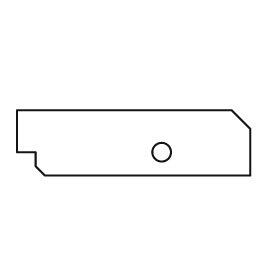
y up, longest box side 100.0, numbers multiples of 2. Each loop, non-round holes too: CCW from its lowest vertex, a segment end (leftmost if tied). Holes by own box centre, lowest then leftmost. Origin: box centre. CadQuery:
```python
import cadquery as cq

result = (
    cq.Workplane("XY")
    .moveTo(-38.0, -14.0)
    .lineTo(50.0, -14.0)
    .lineTo(50.0, 6.0)
    .lineTo(42.0, 14.0)
    .lineTo(-50.0, 14.0)
    .lineTo(-50.0, -4.0)
    .lineTo(-42.0, -4.0)
    .lineTo(-42.0, -10.0)
    .close()
    .moveTo(12.0, -4.0)
    .circle(4.0)
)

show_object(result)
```